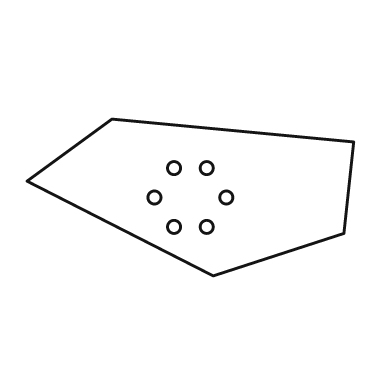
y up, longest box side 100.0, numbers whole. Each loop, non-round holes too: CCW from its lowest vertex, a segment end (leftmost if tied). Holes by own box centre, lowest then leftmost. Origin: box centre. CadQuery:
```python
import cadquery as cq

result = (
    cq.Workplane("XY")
    .moveTo(7.0, -24.0)
    .lineTo(47.0, -11.0)
    .lineTo(50.0, 17.0)
    .lineTo(-24.0, 24.0)
    .lineTo(-50.0, 5.0)
    .close()
    .moveTo(-5.0, -9.0)
    .circle(2.0)
    .moveTo(5.0, -9.0)
    .circle(2.0)
    .moveTo(-11.0, 0.0)
    .circle(2.0)
    .moveTo(11.0, 0.0)
    .circle(2.0)
    .moveTo(-5.0, 9.0)
    .circle(2.0)
    .moveTo(5.0, 9.0)
    .circle(2.0)
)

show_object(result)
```